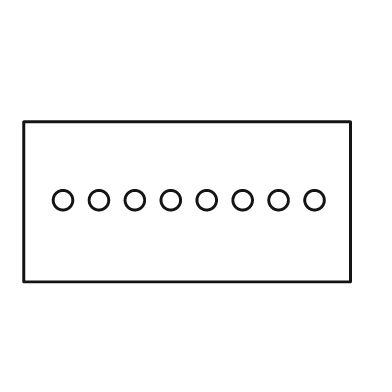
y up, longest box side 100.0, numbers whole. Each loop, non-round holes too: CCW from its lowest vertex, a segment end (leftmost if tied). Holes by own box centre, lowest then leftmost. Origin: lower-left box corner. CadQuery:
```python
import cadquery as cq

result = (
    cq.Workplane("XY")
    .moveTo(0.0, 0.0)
    .lineTo(100.0, 0.0)
    .lineTo(100.0, 49.0)
    .lineTo(0.0, 49.0)
    .close()
    .moveTo(12.0, 25.0)
    .circle(3.0)
    .moveTo(23.0, 25.0)
    .circle(3.0)
    .moveTo(34.0, 25.0)
    .circle(3.0)
    .moveTo(45.0, 25.0)
    .circle(3.0)
    .moveTo(56.0, 25.0)
    .circle(3.0)
    .moveTo(67.0, 25.0)
    .circle(3.0)
    .moveTo(78.0, 25.0)
    .circle(3.0)
    .moveTo(89.0, 25.0)
    .circle(3.0)
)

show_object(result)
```